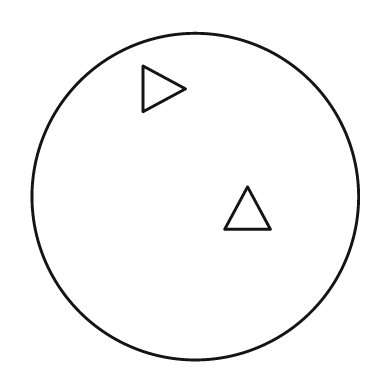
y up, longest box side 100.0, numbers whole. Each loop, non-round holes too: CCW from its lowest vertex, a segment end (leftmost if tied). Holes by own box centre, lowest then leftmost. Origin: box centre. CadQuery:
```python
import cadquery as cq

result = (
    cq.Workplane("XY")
    .moveTo(0.0, 0.0)
    .circle(50.0)
    .moveTo(9.0, -10.0)
    .lineTo(23.0, -10.0)
    .lineTo(16.0, 3.0)
    .close()
    .moveTo(-16.0, 26.0)
    .lineTo(-3.0, 33.0)
    .lineTo(-16.0, 40.0)
    .close()
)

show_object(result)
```